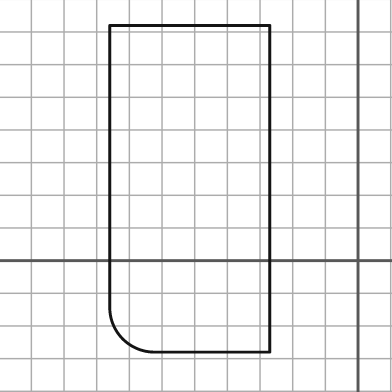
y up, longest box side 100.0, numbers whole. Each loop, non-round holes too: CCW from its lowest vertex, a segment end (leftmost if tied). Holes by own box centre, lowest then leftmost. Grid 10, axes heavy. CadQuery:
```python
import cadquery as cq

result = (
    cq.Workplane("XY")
    .moveTo(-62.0, -28.0)
    .lineTo(-27.0, -28.0)
    .lineTo(-27.0, 72.0)
    .lineTo(-76.0, 72.0)
    .lineTo(-76.0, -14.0)
    .threePointArc((-72.0, -24.0), (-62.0, -28.0))
    .close()
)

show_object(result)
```